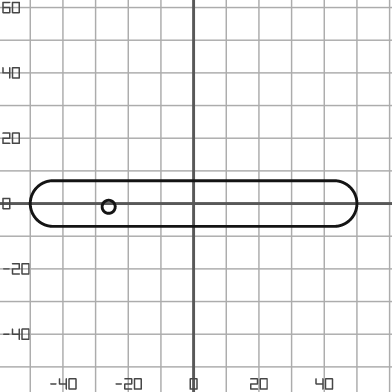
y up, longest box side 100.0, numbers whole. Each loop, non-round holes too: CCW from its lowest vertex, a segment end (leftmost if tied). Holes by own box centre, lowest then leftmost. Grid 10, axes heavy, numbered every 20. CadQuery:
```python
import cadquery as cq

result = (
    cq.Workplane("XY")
    .moveTo(-43.0, -7.0)
    .lineTo(43.0, -7.0)
    .threePointArc((50.0, 0.0), (43.0, 7.0))
    .lineTo(-43.0, 7.0)
    .threePointArc((-50.0, 0.0), (-43.0, -7.0))
    .close()
    .moveTo(-26.0, -1.0)
    .circle(2.0)
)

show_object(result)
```